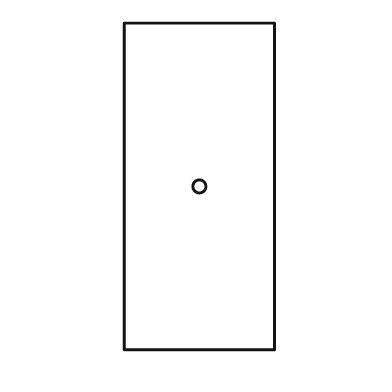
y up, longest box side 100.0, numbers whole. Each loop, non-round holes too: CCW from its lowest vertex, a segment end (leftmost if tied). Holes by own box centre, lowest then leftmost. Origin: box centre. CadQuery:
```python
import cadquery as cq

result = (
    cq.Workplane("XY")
    .moveTo(-23.0, -50.0)
    .lineTo(23.0, -50.0)
    .lineTo(23.0, 50.0)
    .lineTo(-23.0, 50.0)
    .close()
    .moveTo(0.0, 0.0)
    .circle(2.0)
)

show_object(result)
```